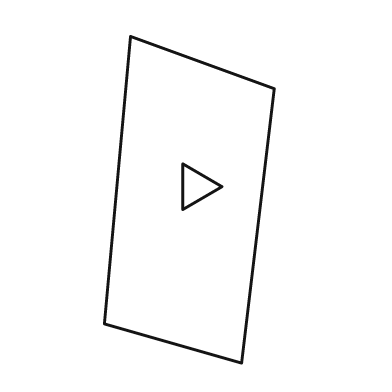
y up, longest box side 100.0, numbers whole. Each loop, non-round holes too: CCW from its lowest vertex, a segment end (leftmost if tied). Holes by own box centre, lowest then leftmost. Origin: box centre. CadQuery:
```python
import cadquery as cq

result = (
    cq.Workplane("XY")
    .moveTo(16.0, -50.0)
    .lineTo(26.0, 34.0)
    .lineTo(-18.0, 50.0)
    .lineTo(-26.0, -38.0)
    .close()
    .moveTo(-2.0, -3.0)
    .lineTo(10.0, 4.0)
    .lineTo(-2.0, 11.0)
    .close()
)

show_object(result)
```